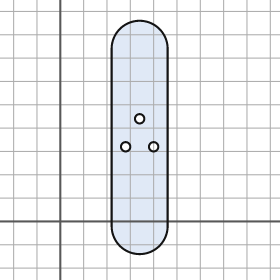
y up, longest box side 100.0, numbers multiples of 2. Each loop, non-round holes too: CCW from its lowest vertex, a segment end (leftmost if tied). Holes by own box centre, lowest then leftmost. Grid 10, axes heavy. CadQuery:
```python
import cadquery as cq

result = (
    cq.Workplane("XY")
    .moveTo(22.0, -2.0)
    .threePointArc((34.0, -14.0), (46.0, -2.0))
    .lineTo(46.0, 74.0)
    .threePointArc((34.0, 86.0), (22.0, 74.0))
    .close()
    .moveTo(28.0, 32.0)
    .circle(2.0)
    .moveTo(40.0, 32.0)
    .circle(2.0)
    .moveTo(34.0, 44.0)
    .circle(2.0)
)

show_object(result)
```